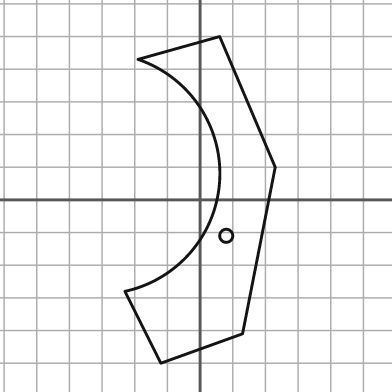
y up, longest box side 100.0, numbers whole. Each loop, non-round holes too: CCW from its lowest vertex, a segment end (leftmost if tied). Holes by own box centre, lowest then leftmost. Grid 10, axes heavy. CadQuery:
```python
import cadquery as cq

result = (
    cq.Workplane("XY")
    .moveTo(-12.0, -50.0)
    .lineTo(13.0, -41.0)
    .lineTo(23.0, 10.0)
    .lineTo(6.0, 50.0)
    .lineTo(-19.0, 43.0)
    .threePointArc((6.0, 6.0), (-23.0, -28.0))
    .close()
    .moveTo(8.0, -11.0)
    .circle(2.0)
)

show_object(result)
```